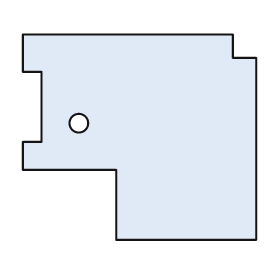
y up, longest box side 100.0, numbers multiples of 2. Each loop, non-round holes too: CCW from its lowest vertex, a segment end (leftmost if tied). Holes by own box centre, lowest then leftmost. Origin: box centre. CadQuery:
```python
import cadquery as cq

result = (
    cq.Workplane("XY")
    .moveTo(-10.0, -44.0)
    .lineTo(50.0, -44.0)
    .lineTo(50.0, 34.0)
    .lineTo(40.0, 34.0)
    .lineTo(40.0, 44.0)
    .lineTo(-50.0, 44.0)
    .lineTo(-50.0, 28.0)
    .lineTo(-42.0, 28.0)
    .lineTo(-42.0, -2.0)
    .lineTo(-50.0, -2.0)
    .lineTo(-50.0, -14.0)
    .lineTo(-10.0, -14.0)
    .close()
    .moveTo(-26.0, 6.0)
    .circle(4.0)
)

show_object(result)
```